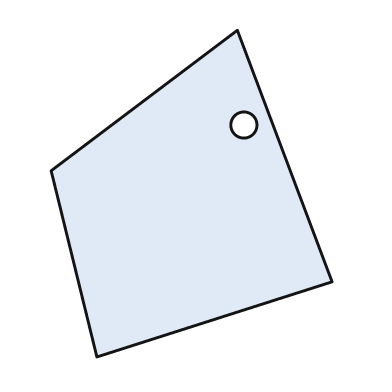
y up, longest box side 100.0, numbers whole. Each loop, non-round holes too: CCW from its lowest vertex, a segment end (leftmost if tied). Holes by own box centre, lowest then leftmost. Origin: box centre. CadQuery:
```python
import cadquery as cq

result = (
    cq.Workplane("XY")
    .moveTo(-29.0, -50.0)
    .lineTo(43.0, -27.0)
    .lineTo(14.0, 50.0)
    .lineTo(-43.0, 7.0)
    .close()
    .moveTo(16.0, 21.0)
    .circle(4.0)
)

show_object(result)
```